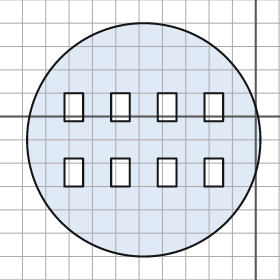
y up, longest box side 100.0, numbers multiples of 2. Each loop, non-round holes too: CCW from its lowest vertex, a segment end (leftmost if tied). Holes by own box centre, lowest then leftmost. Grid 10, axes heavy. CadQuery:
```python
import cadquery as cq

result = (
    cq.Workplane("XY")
    .moveTo(-48.0, -10.0)
    .circle(50.0)
    .moveTo(-82.0, -30.0)
    .lineTo(-74.0, -30.0)
    .lineTo(-74.0, -18.0)
    .lineTo(-82.0, -18.0)
    .close()
    .moveTo(-62.0, -30.0)
    .lineTo(-54.0, -30.0)
    .lineTo(-54.0, -18.0)
    .lineTo(-62.0, -18.0)
    .close()
    .moveTo(-42.0, -30.0)
    .lineTo(-34.0, -30.0)
    .lineTo(-34.0, -18.0)
    .lineTo(-42.0, -18.0)
    .close()
    .moveTo(-22.0, -30.0)
    .lineTo(-14.0, -30.0)
    .lineTo(-14.0, -18.0)
    .lineTo(-22.0, -18.0)
    .close()
    .moveTo(-82.0, -2.0)
    .lineTo(-74.0, -2.0)
    .lineTo(-74.0, 10.0)
    .lineTo(-82.0, 10.0)
    .close()
    .moveTo(-62.0, -2.0)
    .lineTo(-54.0, -2.0)
    .lineTo(-54.0, 10.0)
    .lineTo(-62.0, 10.0)
    .close()
    .moveTo(-42.0, -2.0)
    .lineTo(-34.0, -2.0)
    .lineTo(-34.0, 10.0)
    .lineTo(-42.0, 10.0)
    .close()
    .moveTo(-22.0, -2.0)
    .lineTo(-14.0, -2.0)
    .lineTo(-14.0, 10.0)
    .lineTo(-22.0, 10.0)
    .close()
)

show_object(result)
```